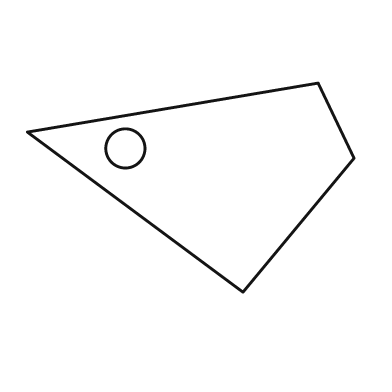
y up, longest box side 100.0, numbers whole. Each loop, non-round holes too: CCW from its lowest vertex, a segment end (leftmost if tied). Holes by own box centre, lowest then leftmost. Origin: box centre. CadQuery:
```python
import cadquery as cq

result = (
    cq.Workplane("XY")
    .moveTo(16.0, -32.0)
    .lineTo(50.0, 9.0)
    .lineTo(39.0, 32.0)
    .lineTo(-50.0, 17.0)
    .close()
    .moveTo(-20.0, 12.0)
    .circle(6.0)
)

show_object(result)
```